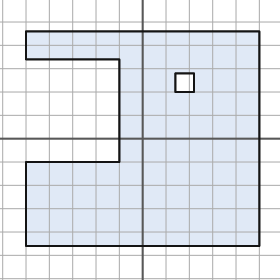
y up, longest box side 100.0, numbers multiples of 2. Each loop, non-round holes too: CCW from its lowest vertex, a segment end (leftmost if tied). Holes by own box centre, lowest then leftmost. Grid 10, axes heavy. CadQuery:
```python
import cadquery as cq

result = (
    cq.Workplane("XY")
    .moveTo(-50.0, -46.0)
    .lineTo(50.0, -46.0)
    .lineTo(50.0, 46.0)
    .lineTo(-50.0, 46.0)
    .lineTo(-50.0, 34.0)
    .lineTo(-10.0, 34.0)
    .lineTo(-10.0, -10.0)
    .lineTo(-50.0, -10.0)
    .close()
    .moveTo(14.0, 20.0)
    .lineTo(22.0, 20.0)
    .lineTo(22.0, 28.0)
    .lineTo(14.0, 28.0)
    .close()
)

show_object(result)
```